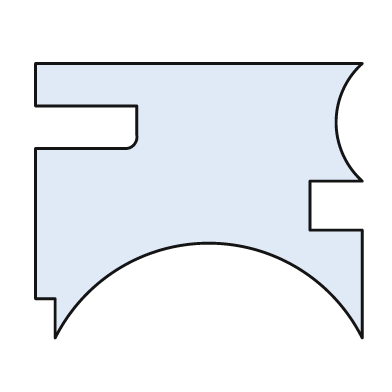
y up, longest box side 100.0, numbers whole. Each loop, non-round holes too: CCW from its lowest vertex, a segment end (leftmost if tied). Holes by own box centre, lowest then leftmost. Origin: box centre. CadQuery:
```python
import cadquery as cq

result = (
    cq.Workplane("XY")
    .moveTo(-44.0, -42.0)
    .threePointArc((3.0, -13.0), (50.0, -42.0))
    .lineTo(50.0, -9.0)
    .lineTo(34.0, -9.0)
    .lineTo(34.0, 6.0)
    .lineTo(50.0, 6.0)
    .threePointArc((42.0, 24.0), (50.0, 42.0))
    .lineTo(-50.0, 42.0)
    .lineTo(-50.0, 29.0)
    .lineTo(-19.0, 29.0)
    .lineTo(-19.0, 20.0)
    .threePointArc((-20.0, 17.0), (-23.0, 16.0))
    .lineTo(-50.0, 16.0)
    .lineTo(-50.0, -30.0)
    .lineTo(-44.0, -30.0)
    .close()
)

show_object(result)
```